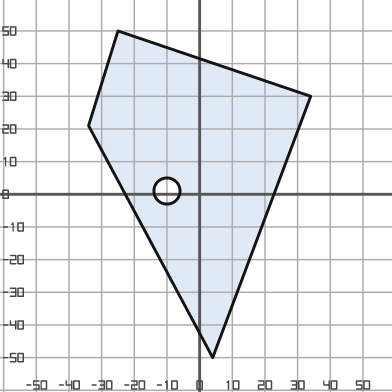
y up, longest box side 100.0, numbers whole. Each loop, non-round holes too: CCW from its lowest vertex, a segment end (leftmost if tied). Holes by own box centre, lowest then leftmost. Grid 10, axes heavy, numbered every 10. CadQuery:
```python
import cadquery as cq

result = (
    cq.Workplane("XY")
    .moveTo(4.0, -50.0)
    .lineTo(34.0, 30.0)
    .lineTo(-25.0, 50.0)
    .lineTo(-34.0, 21.0)
    .close()
    .moveTo(-10.0, 1.0)
    .circle(4.0)
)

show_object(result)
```